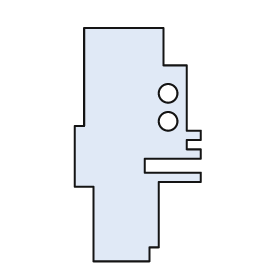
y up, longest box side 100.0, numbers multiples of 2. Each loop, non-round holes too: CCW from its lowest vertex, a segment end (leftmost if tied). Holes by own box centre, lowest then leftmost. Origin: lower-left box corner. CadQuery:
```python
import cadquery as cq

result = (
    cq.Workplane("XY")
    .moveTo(8.0, 0.0)
    .lineTo(32.0, 0.0)
    .lineTo(32.0, 6.0)
    .lineTo(36.0, 6.0)
    .lineTo(36.0, 34.0)
    .lineTo(54.0, 34.0)
    .lineTo(54.0, 38.0)
    .lineTo(30.0, 38.0)
    .lineTo(30.0, 44.0)
    .lineTo(54.0, 44.0)
    .lineTo(54.0, 48.0)
    .lineTo(48.0, 48.0)
    .lineTo(48.0, 52.0)
    .lineTo(54.0, 52.0)
    .lineTo(54.0, 56.0)
    .lineTo(48.0, 56.0)
    .lineTo(48.0, 84.0)
    .lineTo(38.0, 84.0)
    .lineTo(38.0, 100.0)
    .lineTo(4.0, 100.0)
    .lineTo(4.0, 58.0)
    .lineTo(0.0, 58.0)
    .lineTo(0.0, 32.0)
    .lineTo(8.0, 32.0)
    .close()
    .moveTo(40.0, 60.0)
    .circle(4.0)
    .moveTo(40.0, 72.0)
    .circle(4.0)
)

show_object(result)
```